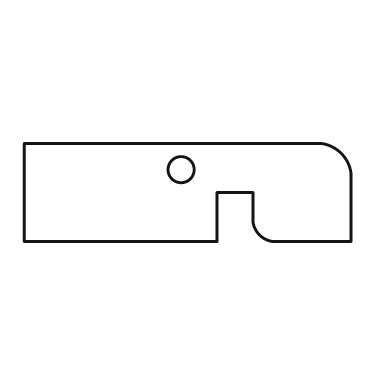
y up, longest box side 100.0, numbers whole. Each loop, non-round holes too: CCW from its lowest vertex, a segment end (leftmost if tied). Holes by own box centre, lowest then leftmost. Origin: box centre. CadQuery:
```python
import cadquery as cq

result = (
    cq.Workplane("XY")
    .moveTo(-50.0, -15.0)
    .lineTo(9.0, -15.0)
    .lineTo(9.0, 0.0)
    .lineTo(20.0, 0.0)
    .lineTo(20.0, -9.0)
    .threePointArc((22.0, -13.0), (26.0, -15.0))
    .lineTo(50.0, -15.0)
    .lineTo(50.0, 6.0)
    .threePointArc((47.0, 12.0), (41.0, 15.0))
    .lineTo(-50.0, 15.0)
    .close()
    .moveTo(-2.0, 7.0)
    .circle(4.0)
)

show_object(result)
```